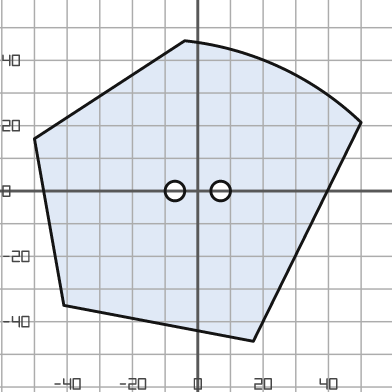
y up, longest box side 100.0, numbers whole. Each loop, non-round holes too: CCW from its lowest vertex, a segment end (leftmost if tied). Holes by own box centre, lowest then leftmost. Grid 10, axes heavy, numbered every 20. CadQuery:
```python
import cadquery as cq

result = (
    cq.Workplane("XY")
    .moveTo(17.0, -46.0)
    .lineTo(50.0, 21.0)
    .threePointArc((25.0, 38.0), (-4.0, 46.0))
    .lineTo(-50.0, 16.0)
    .lineTo(-41.0, -35.0)
    .close()
    .moveTo(-7.0, 0.0)
    .circle(3.0)
    .moveTo(7.0, 0.0)
    .circle(3.0)
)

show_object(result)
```